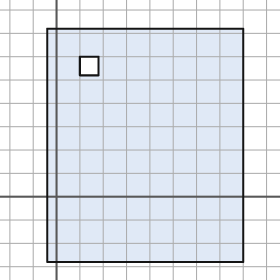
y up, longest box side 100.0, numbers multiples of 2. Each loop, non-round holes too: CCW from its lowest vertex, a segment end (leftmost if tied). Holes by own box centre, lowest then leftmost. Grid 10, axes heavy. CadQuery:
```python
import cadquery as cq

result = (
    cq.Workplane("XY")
    .moveTo(-4.0, -28.0)
    .lineTo(80.0, -28.0)
    .lineTo(80.0, 72.0)
    .lineTo(-4.0, 72.0)
    .close()
    .moveTo(10.0, 52.0)
    .lineTo(18.0, 52.0)
    .lineTo(18.0, 60.0)
    .lineTo(10.0, 60.0)
    .close()
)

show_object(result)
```